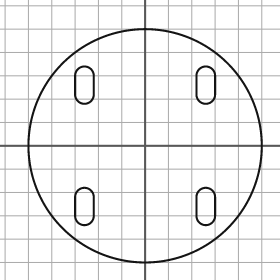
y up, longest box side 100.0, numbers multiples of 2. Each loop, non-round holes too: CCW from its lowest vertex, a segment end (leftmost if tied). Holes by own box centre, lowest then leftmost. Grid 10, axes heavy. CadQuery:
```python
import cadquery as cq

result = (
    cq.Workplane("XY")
    .moveTo(0.0, 0.0)
    .circle(50.0)
    .moveTo(-30.0, -30.0)
    .threePointArc((-26.0, -34.0), (-22.0, -30.0))
    .lineTo(-22.0, -22.0)
    .threePointArc((-26.0, -18.0), (-30.0, -22.0))
    .close()
    .moveTo(22.0, -30.0)
    .threePointArc((26.0, -34.0), (30.0, -30.0))
    .lineTo(30.0, -22.0)
    .threePointArc((26.0, -18.0), (22.0, -22.0))
    .close()
    .moveTo(-30.0, 22.0)
    .threePointArc((-26.0, 18.0), (-22.0, 22.0))
    .lineTo(-22.0, 30.0)
    .threePointArc((-26.0, 34.0), (-30.0, 30.0))
    .close()
    .moveTo(22.0, 22.0)
    .threePointArc((26.0, 18.0), (30.0, 22.0))
    .lineTo(30.0, 30.0)
    .threePointArc((26.0, 34.0), (22.0, 30.0))
    .close()
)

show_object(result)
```